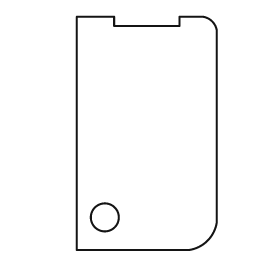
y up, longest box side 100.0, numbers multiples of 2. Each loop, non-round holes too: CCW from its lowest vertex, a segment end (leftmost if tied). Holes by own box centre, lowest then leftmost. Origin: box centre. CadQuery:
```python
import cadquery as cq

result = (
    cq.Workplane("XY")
    .moveTo(-30.0, -50.0)
    .lineTo(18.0, -50.0)
    .threePointArc((26.0, -46.0), (30.0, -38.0))
    .lineTo(30.0, 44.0)
    .threePointArc((28.0, 48.0), (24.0, 50.0))
    .lineTo(14.0, 50.0)
    .lineTo(14.0, 46.0)
    .lineTo(-14.0, 46.0)
    .lineTo(-14.0, 50.0)
    .lineTo(-30.0, 50.0)
    .close()
    .moveTo(-18.0, -36.0)
    .circle(6.0)
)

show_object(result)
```